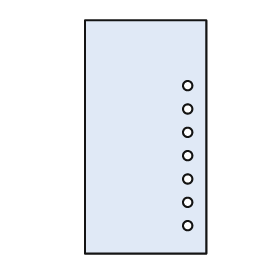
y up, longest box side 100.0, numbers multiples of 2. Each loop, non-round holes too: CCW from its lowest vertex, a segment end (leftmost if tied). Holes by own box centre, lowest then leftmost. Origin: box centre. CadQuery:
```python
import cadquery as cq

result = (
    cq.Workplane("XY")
    .moveTo(-26.0, -50.0)
    .lineTo(26.0, -50.0)
    .lineTo(26.0, 50.0)
    .lineTo(-26.0, 50.0)
    .close()
    .moveTo(18.0, -38.0)
    .circle(2.0)
    .moveTo(18.0, -28.0)
    .circle(2.0)
    .moveTo(18.0, -18.0)
    .circle(2.0)
    .moveTo(18.0, -8.0)
    .circle(2.0)
    .moveTo(18.0, 2.0)
    .circle(2.0)
    .moveTo(18.0, 12.0)
    .circle(2.0)
    .moveTo(18.0, 22.0)
    .circle(2.0)
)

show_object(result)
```